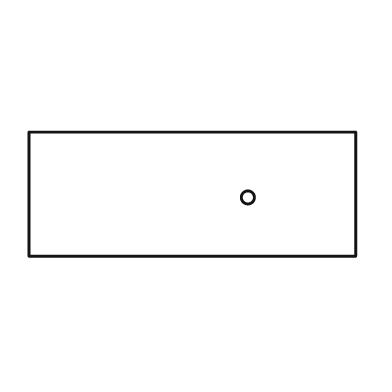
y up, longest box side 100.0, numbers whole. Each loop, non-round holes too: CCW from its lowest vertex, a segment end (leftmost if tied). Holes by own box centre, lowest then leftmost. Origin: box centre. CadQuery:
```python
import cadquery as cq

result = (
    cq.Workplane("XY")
    .moveTo(-50.0, -19.0)
    .lineTo(50.0, -19.0)
    .lineTo(50.0, 19.0)
    .lineTo(-50.0, 19.0)
    .close()
    .moveTo(17.0, -1.0)
    .circle(2.0)
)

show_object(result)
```